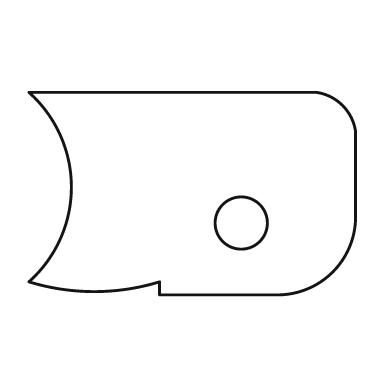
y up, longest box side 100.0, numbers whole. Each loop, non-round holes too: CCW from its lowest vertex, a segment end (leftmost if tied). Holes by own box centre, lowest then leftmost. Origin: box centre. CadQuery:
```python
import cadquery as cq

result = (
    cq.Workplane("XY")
    .moveTo(-10.0, -31.0)
    .lineTo(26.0, -31.0)
    .threePointArc((43.0, -24.0), (50.0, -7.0))
    .lineTo(50.0, 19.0)
    .threePointArc((46.0, 27.0), (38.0, 31.0))
    .lineTo(-50.0, 31.0)
    .threePointArc((-37.0, 2.0), (-50.0, -27.0))
    .threePointArc((-30.0, -30.0), (-10.0, -27.0))
    .close()
    .moveTo(15.0, -9.0)
    .circle(8.0)
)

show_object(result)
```